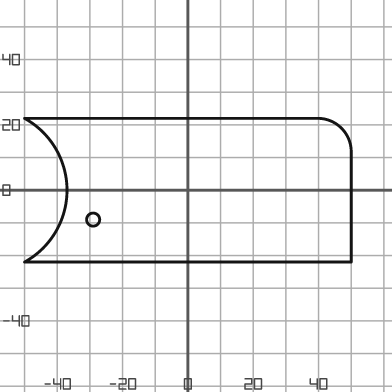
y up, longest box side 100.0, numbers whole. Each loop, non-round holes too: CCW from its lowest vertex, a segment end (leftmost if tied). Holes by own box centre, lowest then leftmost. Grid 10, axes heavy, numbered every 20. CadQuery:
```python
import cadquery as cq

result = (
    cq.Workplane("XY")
    .moveTo(-50.0, -22.0)
    .lineTo(50.0, -22.0)
    .lineTo(50.0, 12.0)
    .threePointArc((47.0, 19.0), (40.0, 22.0))
    .lineTo(-50.0, 22.0)
    .threePointArc((-37.0, 0.0), (-50.0, -22.0))
    .close()
    .moveTo(-29.0, -9.0)
    .circle(2.0)
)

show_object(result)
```